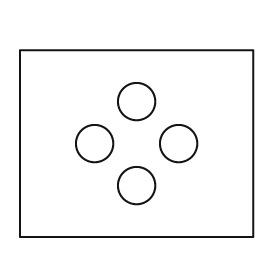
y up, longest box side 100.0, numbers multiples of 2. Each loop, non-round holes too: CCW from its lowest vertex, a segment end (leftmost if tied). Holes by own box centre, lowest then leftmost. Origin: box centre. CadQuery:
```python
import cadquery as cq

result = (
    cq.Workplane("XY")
    .moveTo(-50.0, -40.0)
    .lineTo(50.0, -40.0)
    .lineTo(50.0, 40.0)
    .lineTo(-50.0, 40.0)
    .close()
    .moveTo(0.0, -18.0)
    .circle(8.0)
    .moveTo(-18.0, 0.0)
    .circle(8.0)
    .moveTo(18.0, 0.0)
    .circle(8.0)
    .moveTo(0.0, 18.0)
    .circle(8.0)
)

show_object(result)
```